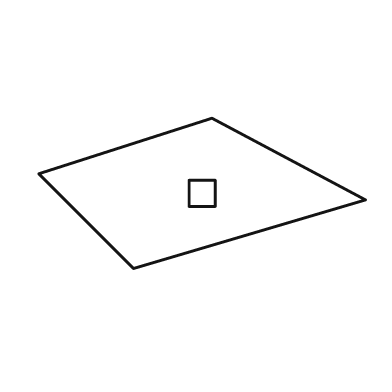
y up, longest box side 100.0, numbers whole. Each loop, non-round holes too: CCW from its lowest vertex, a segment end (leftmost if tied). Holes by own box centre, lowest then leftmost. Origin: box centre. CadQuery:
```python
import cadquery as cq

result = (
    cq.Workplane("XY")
    .moveTo(-21.0, -23.0)
    .lineTo(50.0, -2.0)
    .lineTo(3.0, 23.0)
    .lineTo(-50.0, 6.0)
    .close()
    .moveTo(-4.0, -4.0)
    .lineTo(4.0, -4.0)
    .lineTo(4.0, 4.0)
    .lineTo(-4.0, 4.0)
    .close()
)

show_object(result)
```